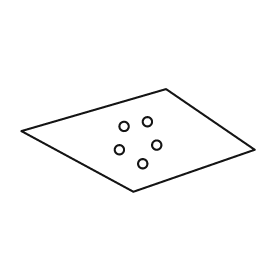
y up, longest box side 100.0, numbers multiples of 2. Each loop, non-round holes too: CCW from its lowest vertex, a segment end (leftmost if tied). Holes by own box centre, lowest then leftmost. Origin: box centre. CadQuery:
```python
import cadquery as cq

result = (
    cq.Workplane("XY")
    .moveTo(-2.0, -22.0)
    .lineTo(50.0, -4.0)
    .lineTo(12.0, 22.0)
    .lineTo(-50.0, 4.0)
    .close()
    .moveTo(2.0, -10.0)
    .circle(2.0)
    .moveTo(-8.0, -4.0)
    .circle(2.0)
    .moveTo(8.0, -2.0)
    .circle(2.0)
    .moveTo(-6.0, 6.0)
    .circle(2.0)
    .moveTo(4.0, 8.0)
    .circle(2.0)
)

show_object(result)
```